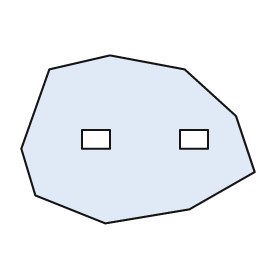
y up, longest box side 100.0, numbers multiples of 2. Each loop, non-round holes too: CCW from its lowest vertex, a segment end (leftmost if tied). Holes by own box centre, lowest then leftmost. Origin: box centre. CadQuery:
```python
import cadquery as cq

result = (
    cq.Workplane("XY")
    .moveTo(-14.0, -36.0)
    .lineTo(22.0, -30.0)
    .lineTo(50.0, -14.0)
    .lineTo(42.0, 10.0)
    .lineTo(20.0, 30.0)
    .lineTo(-12.0, 36.0)
    .lineTo(-38.0, 30.0)
    .lineTo(-50.0, -4.0)
    .lineTo(-44.0, -24.0)
    .close()
    .moveTo(-24.0, -4.0)
    .lineTo(-12.0, -4.0)
    .lineTo(-12.0, 4.0)
    .lineTo(-24.0, 4.0)
    .close()
    .moveTo(18.0, -4.0)
    .lineTo(30.0, -4.0)
    .lineTo(30.0, 4.0)
    .lineTo(18.0, 4.0)
    .close()
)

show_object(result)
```